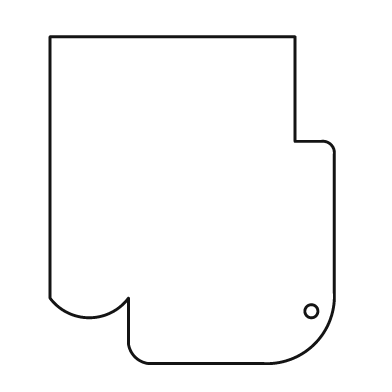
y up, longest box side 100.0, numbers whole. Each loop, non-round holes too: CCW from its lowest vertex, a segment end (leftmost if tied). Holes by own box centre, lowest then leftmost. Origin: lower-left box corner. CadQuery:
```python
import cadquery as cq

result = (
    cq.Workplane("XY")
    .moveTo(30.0, 0.0)
    .lineTo(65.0, 0.0)
    .threePointArc((81.0, 6.0), (87.0, 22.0))
    .lineTo(87.0, 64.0)
    .threePointArc((86.0, 67.0), (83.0, 68.0))
    .lineTo(75.0, 68.0)
    .lineTo(75.0, 100.0)
    .lineTo(0.0, 100.0)
    .lineTo(0.0, 20.0)
    .threePointArc((12.0, 14.0), (24.0, 20.0))
    .lineTo(24.0, 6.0)
    .threePointArc((26.0, 2.0), (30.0, 0.0))
    .close()
    .moveTo(80.0, 16.0)
    .circle(2.0)
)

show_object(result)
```